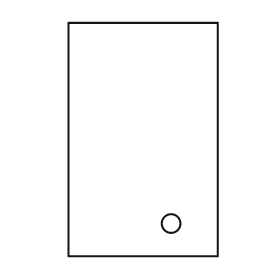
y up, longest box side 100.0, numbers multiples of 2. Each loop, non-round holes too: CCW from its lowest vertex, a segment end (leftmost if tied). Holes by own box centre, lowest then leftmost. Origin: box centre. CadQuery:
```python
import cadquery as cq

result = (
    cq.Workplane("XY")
    .moveTo(-32.0, -50.0)
    .lineTo(32.0, -50.0)
    .lineTo(32.0, 50.0)
    .lineTo(-32.0, 50.0)
    .close()
    .moveTo(12.0, -36.0)
    .circle(4.0)
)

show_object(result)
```